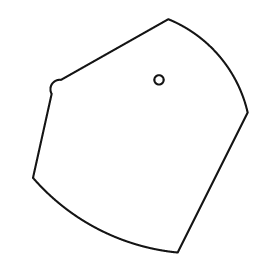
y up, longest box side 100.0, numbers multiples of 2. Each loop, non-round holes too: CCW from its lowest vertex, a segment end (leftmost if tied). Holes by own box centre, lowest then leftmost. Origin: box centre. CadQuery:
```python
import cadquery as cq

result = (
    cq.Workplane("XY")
    .moveTo(16.0, -50.0)
    .lineTo(46.0, 10.0)
    .threePointArc((34.0, 34.0), (12.0, 50.0))
    .lineTo(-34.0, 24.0)
    .threePointArc((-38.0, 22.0), (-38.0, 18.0))
    .lineTo(-46.0, -18.0)
    .threePointArc((-18.0, -40.0), (16.0, -50.0))
    .close()
    .moveTo(8.0, 24.0)
    .circle(2.0)
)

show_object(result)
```